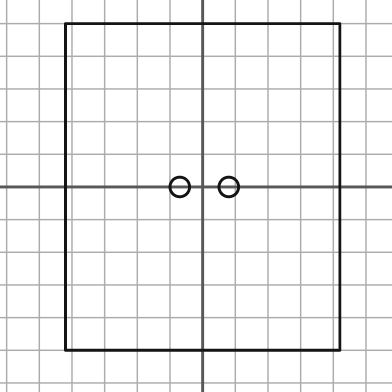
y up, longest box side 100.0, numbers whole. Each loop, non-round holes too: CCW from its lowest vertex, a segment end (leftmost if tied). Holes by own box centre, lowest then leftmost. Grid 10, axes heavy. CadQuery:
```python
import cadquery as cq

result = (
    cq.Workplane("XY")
    .moveTo(-42.0, -50.0)
    .lineTo(42.0, -50.0)
    .lineTo(42.0, 50.0)
    .lineTo(-42.0, 50.0)
    .close()
    .moveTo(-7.0, 0.0)
    .circle(3.0)
    .moveTo(8.0, 0.0)
    .circle(3.0)
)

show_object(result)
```